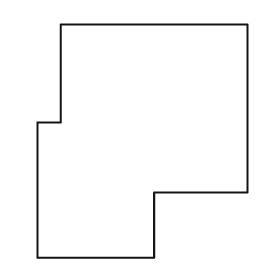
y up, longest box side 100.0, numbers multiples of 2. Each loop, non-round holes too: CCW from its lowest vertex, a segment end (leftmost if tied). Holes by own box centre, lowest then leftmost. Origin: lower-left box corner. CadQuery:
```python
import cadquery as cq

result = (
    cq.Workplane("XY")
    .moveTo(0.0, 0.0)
    .lineTo(50.0, 0.0)
    .lineTo(50.0, 28.0)
    .lineTo(90.0, 28.0)
    .lineTo(90.0, 100.0)
    .lineTo(10.0, 100.0)
    .lineTo(10.0, 58.0)
    .lineTo(0.0, 58.0)
    .close()
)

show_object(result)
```